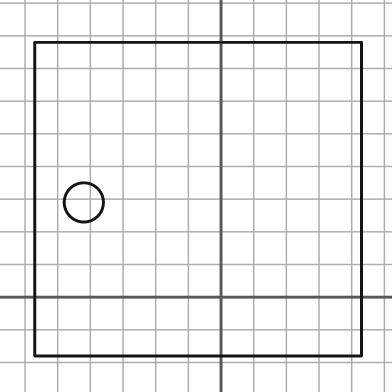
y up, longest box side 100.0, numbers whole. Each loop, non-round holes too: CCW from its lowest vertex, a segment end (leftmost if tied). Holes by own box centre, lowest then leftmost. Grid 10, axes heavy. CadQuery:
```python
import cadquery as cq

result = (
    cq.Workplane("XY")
    .moveTo(-57.0, -18.0)
    .lineTo(43.0, -18.0)
    .lineTo(43.0, 78.0)
    .lineTo(-57.0, 78.0)
    .close()
    .moveTo(-42.0, 29.0)
    .circle(6.0)
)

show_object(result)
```